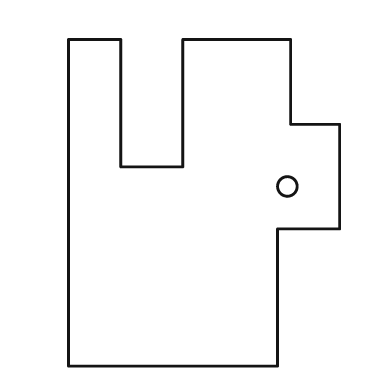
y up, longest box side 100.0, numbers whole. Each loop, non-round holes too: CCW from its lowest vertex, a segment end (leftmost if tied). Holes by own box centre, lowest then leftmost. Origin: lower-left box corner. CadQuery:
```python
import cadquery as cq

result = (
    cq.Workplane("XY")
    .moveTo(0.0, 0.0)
    .lineTo(64.0, 0.0)
    .lineTo(64.0, 42.0)
    .lineTo(83.0, 42.0)
    .lineTo(83.0, 74.0)
    .lineTo(68.0, 74.0)
    .lineTo(68.0, 100.0)
    .lineTo(35.0, 100.0)
    .lineTo(35.0, 61.0)
    .lineTo(16.0, 61.0)
    .lineTo(16.0, 100.0)
    .lineTo(0.0, 100.0)
    .close()
    .moveTo(67.0, 55.0)
    .circle(3.0)
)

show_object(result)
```